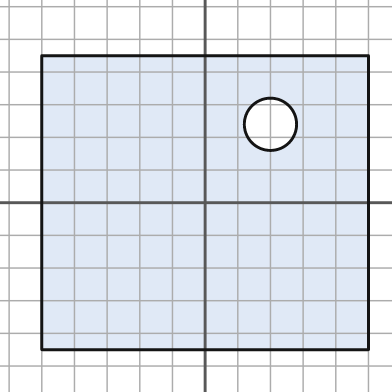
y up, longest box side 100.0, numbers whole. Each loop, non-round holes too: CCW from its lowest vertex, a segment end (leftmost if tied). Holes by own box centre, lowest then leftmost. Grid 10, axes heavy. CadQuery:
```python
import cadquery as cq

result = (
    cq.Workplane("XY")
    .moveTo(-50.0, -45.0)
    .lineTo(50.0, -45.0)
    .lineTo(50.0, 45.0)
    .lineTo(-50.0, 45.0)
    .close()
    .moveTo(20.0, 24.0)
    .circle(8.0)
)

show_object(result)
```